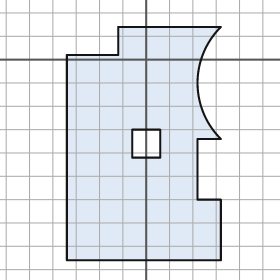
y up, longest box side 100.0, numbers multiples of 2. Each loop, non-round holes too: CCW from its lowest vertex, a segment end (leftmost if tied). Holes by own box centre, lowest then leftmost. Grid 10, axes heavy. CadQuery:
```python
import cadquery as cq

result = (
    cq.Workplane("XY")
    .moveTo(-34.0, -86.0)
    .lineTo(32.0, -86.0)
    .lineTo(32.0, -60.0)
    .lineTo(22.0, -60.0)
    .lineTo(22.0, -34.0)
    .lineTo(32.0, -34.0)
    .threePointArc((22.0, -10.0), (32.0, 14.0))
    .lineTo(-12.0, 14.0)
    .lineTo(-12.0, 2.0)
    .lineTo(-34.0, 2.0)
    .close()
    .moveTo(-6.0, -42.0)
    .lineTo(6.0, -42.0)
    .lineTo(6.0, -30.0)
    .lineTo(-6.0, -30.0)
    .close()
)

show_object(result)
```